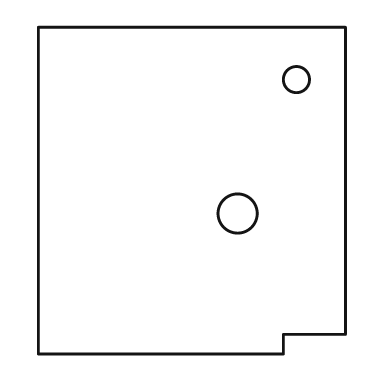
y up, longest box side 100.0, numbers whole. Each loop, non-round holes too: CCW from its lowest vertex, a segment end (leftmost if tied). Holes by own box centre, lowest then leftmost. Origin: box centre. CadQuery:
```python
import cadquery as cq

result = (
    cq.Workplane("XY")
    .moveTo(-47.0, -50.0)
    .lineTo(28.0, -50.0)
    .lineTo(28.0, -44.0)
    .lineTo(47.0, -44.0)
    .lineTo(47.0, 50.0)
    .lineTo(-47.0, 50.0)
    .close()
    .moveTo(14.0, -7.0)
    .circle(6.0)
    .moveTo(32.0, 34.0)
    .circle(4.0)
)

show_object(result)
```